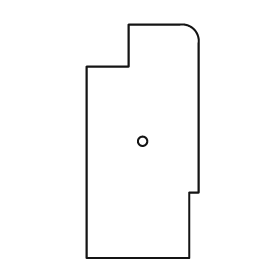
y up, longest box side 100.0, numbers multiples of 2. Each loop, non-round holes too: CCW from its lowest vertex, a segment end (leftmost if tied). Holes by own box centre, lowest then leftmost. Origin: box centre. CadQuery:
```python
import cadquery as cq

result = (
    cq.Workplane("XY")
    .moveTo(-24.0, -50.0)
    .lineTo(20.0, -50.0)
    .lineTo(20.0, -22.0)
    .lineTo(24.0, -22.0)
    .lineTo(24.0, 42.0)
    .threePointArc((22.0, 48.0), (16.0, 50.0))
    .lineTo(-6.0, 50.0)
    .lineTo(-6.0, 32.0)
    .lineTo(-24.0, 32.0)
    .close()
    .moveTo(0.0, 0.0)
    .circle(2.0)
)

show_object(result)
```